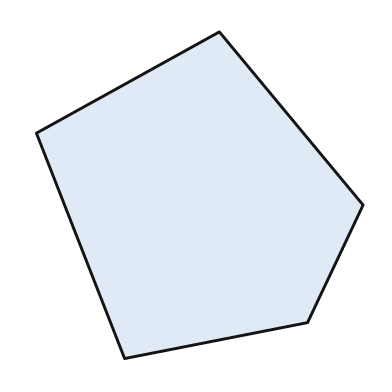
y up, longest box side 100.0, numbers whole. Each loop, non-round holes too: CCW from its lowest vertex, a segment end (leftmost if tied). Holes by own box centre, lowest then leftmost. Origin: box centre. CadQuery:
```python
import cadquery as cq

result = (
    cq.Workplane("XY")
    .moveTo(-23.0, -50.0)
    .lineTo(33.0, -39.0)
    .lineTo(50.0, -3.0)
    .lineTo(6.0, 50.0)
    .lineTo(-50.0, 19.0)
    .close()
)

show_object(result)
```